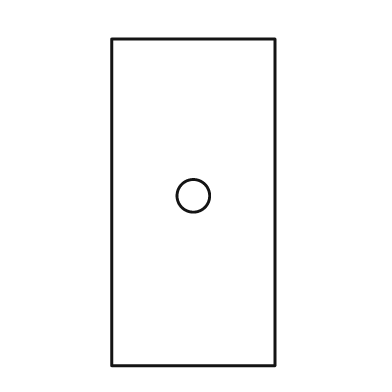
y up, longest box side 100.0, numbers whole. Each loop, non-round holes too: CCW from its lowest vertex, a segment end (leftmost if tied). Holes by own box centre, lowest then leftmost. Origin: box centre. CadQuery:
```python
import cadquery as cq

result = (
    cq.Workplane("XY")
    .moveTo(-25.0, -50.0)
    .lineTo(25.0, -50.0)
    .lineTo(25.0, 50.0)
    .lineTo(-25.0, 50.0)
    .close()
    .moveTo(0.0, 2.0)
    .circle(5.0)
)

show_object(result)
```